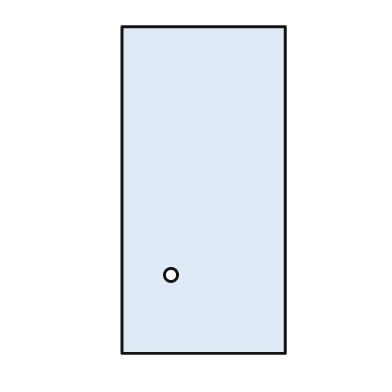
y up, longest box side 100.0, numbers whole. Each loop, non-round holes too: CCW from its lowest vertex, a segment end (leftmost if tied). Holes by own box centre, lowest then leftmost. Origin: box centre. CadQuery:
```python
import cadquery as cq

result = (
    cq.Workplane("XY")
    .moveTo(-25.0, -50.0)
    .lineTo(25.0, -50.0)
    .lineTo(25.0, 50.0)
    .lineTo(-25.0, 50.0)
    .close()
    .moveTo(-10.0, -26.0)
    .circle(2.0)
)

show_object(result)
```